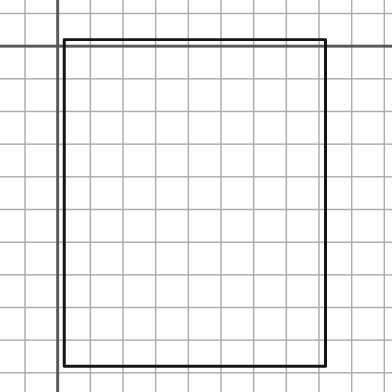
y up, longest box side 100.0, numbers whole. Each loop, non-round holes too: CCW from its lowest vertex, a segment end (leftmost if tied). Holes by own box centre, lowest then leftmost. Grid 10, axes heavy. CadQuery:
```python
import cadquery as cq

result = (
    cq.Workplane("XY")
    .moveTo(2.0, -98.0)
    .lineTo(82.0, -98.0)
    .lineTo(82.0, 2.0)
    .lineTo(2.0, 2.0)
    .close()
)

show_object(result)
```